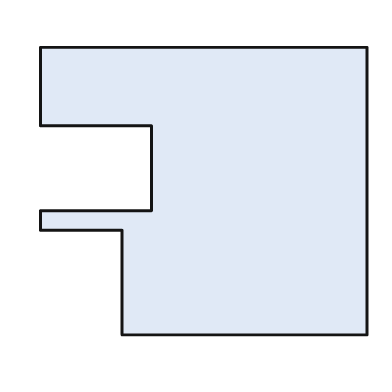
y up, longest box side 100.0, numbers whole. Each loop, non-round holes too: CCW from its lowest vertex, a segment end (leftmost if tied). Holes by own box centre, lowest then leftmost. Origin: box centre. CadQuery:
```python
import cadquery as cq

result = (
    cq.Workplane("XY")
    .moveTo(-25.0, -44.0)
    .lineTo(50.0, -44.0)
    .lineTo(50.0, 44.0)
    .lineTo(-50.0, 44.0)
    .lineTo(-50.0, 20.0)
    .lineTo(-16.0, 20.0)
    .lineTo(-16.0, -6.0)
    .lineTo(-50.0, -6.0)
    .lineTo(-50.0, -12.0)
    .lineTo(-25.0, -12.0)
    .close()
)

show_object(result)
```